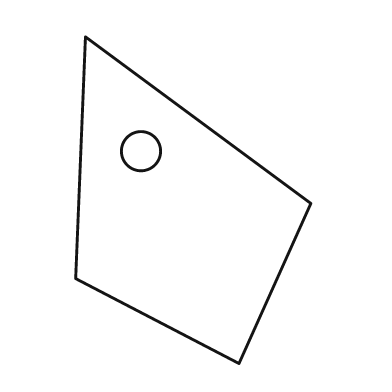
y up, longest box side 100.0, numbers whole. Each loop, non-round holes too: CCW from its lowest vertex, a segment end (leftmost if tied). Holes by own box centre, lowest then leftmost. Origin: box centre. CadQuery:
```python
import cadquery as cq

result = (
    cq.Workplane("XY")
    .moveTo(14.0, -50.0)
    .lineTo(36.0, -1.0)
    .lineTo(-33.0, 50.0)
    .lineTo(-36.0, -24.0)
    .close()
    .moveTo(-16.0, 15.0)
    .circle(6.0)
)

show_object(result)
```